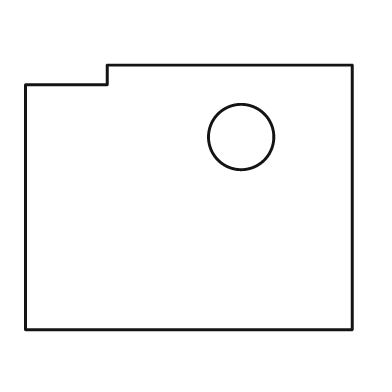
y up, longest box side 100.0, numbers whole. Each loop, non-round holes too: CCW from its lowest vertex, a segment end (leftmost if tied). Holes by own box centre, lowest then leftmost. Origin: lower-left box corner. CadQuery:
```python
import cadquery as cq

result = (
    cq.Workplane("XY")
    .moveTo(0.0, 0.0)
    .lineTo(100.0, 0.0)
    .lineTo(100.0, 81.0)
    .lineTo(25.0, 81.0)
    .lineTo(25.0, 75.0)
    .lineTo(0.0, 75.0)
    .close()
    .moveTo(66.0, 59.0)
    .circle(10.0)
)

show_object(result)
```